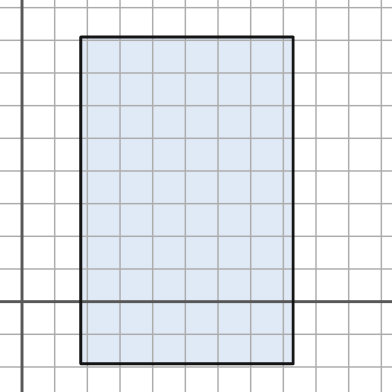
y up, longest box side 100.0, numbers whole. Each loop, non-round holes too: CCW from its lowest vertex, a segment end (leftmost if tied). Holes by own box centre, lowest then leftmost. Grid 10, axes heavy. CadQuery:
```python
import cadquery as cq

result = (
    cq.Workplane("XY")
    .moveTo(18.0, -19.0)
    .lineTo(83.0, -19.0)
    .lineTo(83.0, 81.0)
    .lineTo(18.0, 81.0)
    .close()
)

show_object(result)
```